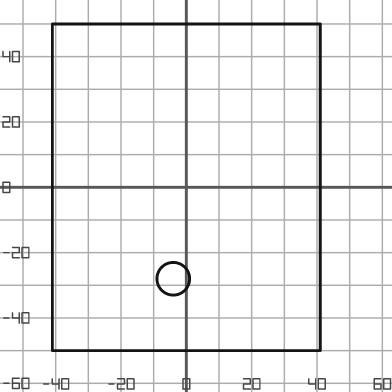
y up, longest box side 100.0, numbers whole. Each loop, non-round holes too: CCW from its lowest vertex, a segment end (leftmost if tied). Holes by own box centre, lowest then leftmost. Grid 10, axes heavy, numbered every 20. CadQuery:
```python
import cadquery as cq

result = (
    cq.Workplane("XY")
    .moveTo(-41.0, -50.0)
    .lineTo(41.0, -50.0)
    .lineTo(41.0, 50.0)
    .lineTo(-41.0, 50.0)
    .close()
    .moveTo(-4.0, -28.0)
    .circle(5.0)
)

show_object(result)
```